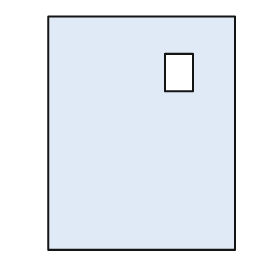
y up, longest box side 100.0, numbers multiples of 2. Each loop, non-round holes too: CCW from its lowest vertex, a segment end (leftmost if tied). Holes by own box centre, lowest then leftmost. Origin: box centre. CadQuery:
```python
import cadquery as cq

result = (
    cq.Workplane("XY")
    .moveTo(-40.0, -50.0)
    .lineTo(40.0, -50.0)
    .lineTo(40.0, 50.0)
    .lineTo(-40.0, 50.0)
    .close()
    .moveTo(10.0, 18.0)
    .lineTo(22.0, 18.0)
    .lineTo(22.0, 34.0)
    .lineTo(10.0, 34.0)
    .close()
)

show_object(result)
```